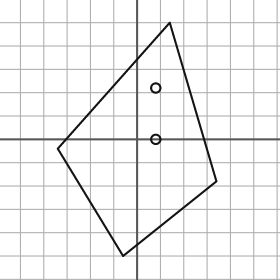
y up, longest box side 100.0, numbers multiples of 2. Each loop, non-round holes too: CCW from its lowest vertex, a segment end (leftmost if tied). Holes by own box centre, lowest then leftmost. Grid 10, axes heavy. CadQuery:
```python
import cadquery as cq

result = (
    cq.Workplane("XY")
    .moveTo(-6.0, -50.0)
    .lineTo(34.0, -18.0)
    .lineTo(14.0, 50.0)
    .lineTo(-34.0, -4.0)
    .close()
    .moveTo(8.0, 0.0)
    .circle(2.0)
    .moveTo(8.0, 22.0)
    .circle(2.0)
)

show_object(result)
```